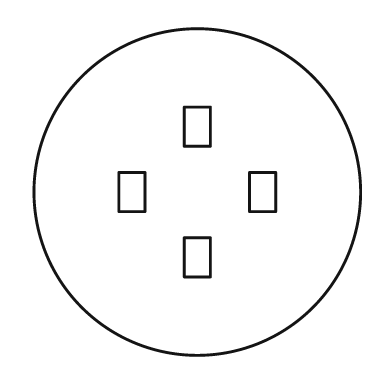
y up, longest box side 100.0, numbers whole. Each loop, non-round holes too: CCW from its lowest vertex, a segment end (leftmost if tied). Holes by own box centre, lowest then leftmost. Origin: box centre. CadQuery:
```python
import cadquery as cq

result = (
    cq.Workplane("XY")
    .moveTo(0.0, 0.0)
    .circle(50.0)
    .moveTo(-4.0, -26.0)
    .lineTo(4.0, -26.0)
    .lineTo(4.0, -14.0)
    .lineTo(-4.0, -14.0)
    .close()
    .moveTo(-24.0, -6.0)
    .lineTo(-16.0, -6.0)
    .lineTo(-16.0, 6.0)
    .lineTo(-24.0, 6.0)
    .close()
    .moveTo(16.0, -6.0)
    .lineTo(24.0, -6.0)
    .lineTo(24.0, 6.0)
    .lineTo(16.0, 6.0)
    .close()
    .moveTo(-4.0, 14.0)
    .lineTo(4.0, 14.0)
    .lineTo(4.0, 26.0)
    .lineTo(-4.0, 26.0)
    .close()
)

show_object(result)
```